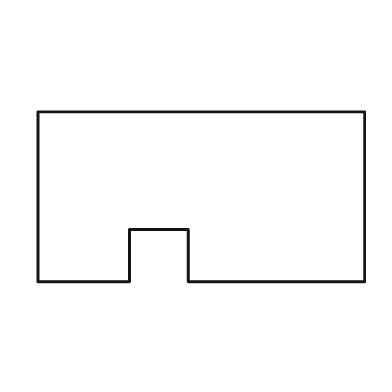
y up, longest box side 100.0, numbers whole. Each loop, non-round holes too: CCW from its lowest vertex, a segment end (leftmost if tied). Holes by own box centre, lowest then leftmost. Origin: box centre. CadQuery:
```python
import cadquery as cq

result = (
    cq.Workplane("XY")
    .moveTo(-50.0, -26.0)
    .lineTo(-22.0, -26.0)
    .lineTo(-22.0, -10.0)
    .lineTo(-4.0, -10.0)
    .lineTo(-4.0, -26.0)
    .lineTo(50.0, -26.0)
    .lineTo(50.0, 26.0)
    .lineTo(-50.0, 26.0)
    .close()
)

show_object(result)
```